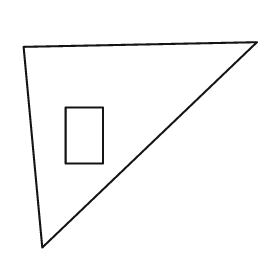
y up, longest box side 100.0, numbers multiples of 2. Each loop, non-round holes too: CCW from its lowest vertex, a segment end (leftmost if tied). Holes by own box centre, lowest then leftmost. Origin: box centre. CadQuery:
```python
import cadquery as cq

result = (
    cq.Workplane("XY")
    .moveTo(-42.0, -44.0)
    .lineTo(50.0, 44.0)
    .lineTo(-50.0, 42.0)
    .close()
    .moveTo(-32.0, -8.0)
    .lineTo(-16.0, -8.0)
    .lineTo(-16.0, 16.0)
    .lineTo(-32.0, 16.0)
    .close()
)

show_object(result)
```